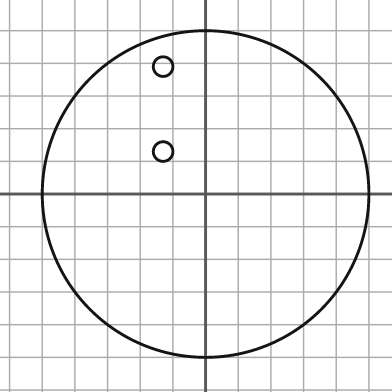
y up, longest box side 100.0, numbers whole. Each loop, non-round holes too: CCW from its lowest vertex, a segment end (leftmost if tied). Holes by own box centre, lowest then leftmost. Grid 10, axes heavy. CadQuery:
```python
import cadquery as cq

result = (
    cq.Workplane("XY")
    .moveTo(0.0, 0.0)
    .circle(50.0)
    .moveTo(-13.0, 13.0)
    .circle(3.0)
    .moveTo(-13.0, 39.0)
    .circle(3.0)
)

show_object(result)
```